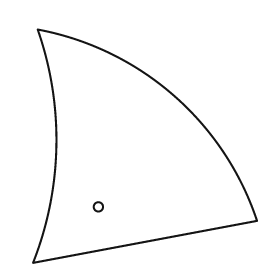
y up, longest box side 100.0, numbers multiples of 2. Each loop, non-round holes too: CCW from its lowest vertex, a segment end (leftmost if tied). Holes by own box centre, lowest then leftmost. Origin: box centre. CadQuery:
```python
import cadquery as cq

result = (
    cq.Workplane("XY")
    .moveTo(-48.0, -50.0)
    .lineTo(48.0, -32.0)
    .threePointArc((12.0, 22.0), (-46.0, 50.0))
    .threePointArc((-38.0, 0.0), (-48.0, -50.0))
    .close()
    .moveTo(-20.0, -26.0)
    .circle(2.0)
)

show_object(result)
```